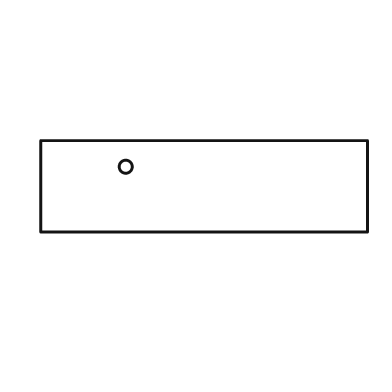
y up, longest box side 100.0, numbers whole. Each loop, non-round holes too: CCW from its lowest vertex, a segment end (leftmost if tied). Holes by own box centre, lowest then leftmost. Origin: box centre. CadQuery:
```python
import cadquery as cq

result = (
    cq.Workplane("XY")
    .moveTo(-50.0, -14.0)
    .lineTo(50.0, -14.0)
    .lineTo(50.0, 14.0)
    .lineTo(-50.0, 14.0)
    .close()
    .moveTo(-24.0, 6.0)
    .circle(2.0)
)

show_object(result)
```